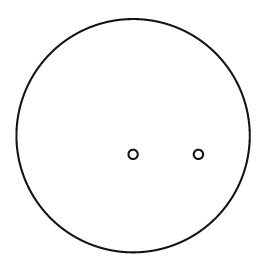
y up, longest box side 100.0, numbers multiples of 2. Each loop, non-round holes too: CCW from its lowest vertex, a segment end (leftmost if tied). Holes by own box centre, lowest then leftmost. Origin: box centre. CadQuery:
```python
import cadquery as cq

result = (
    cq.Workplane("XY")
    .moveTo(0.0, 0.0)
    .circle(50.0)
    .moveTo(0.0, -8.0)
    .circle(2.0)
    .moveTo(28.0, -8.0)
    .circle(2.0)
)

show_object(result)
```